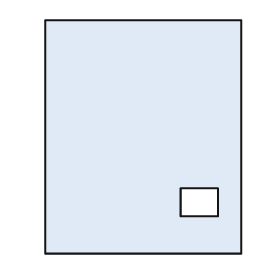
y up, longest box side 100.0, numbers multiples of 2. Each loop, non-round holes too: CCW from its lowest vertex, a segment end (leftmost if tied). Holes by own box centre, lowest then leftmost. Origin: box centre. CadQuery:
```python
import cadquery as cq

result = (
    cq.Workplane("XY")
    .moveTo(-42.0, -50.0)
    .lineTo(42.0, -50.0)
    .lineTo(42.0, 50.0)
    .lineTo(-42.0, 50.0)
    .close()
    .moveTo(16.0, -34.0)
    .lineTo(32.0, -34.0)
    .lineTo(32.0, -22.0)
    .lineTo(16.0, -22.0)
    .close()
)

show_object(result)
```